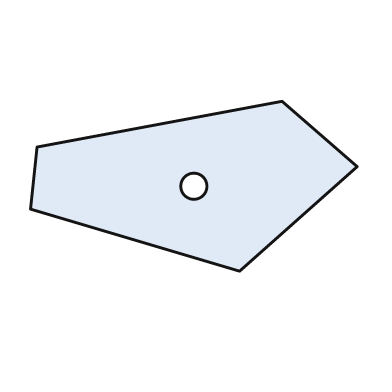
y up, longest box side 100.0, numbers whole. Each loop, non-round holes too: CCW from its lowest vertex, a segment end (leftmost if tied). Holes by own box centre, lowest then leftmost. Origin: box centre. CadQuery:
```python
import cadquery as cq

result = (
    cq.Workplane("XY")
    .moveTo(14.0, -26.0)
    .lineTo(50.0, 6.0)
    .lineTo(27.0, 26.0)
    .lineTo(-48.0, 12.0)
    .lineTo(-50.0, -7.0)
    .close()
    .moveTo(0.0, 0.0)
    .circle(4.0)
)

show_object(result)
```